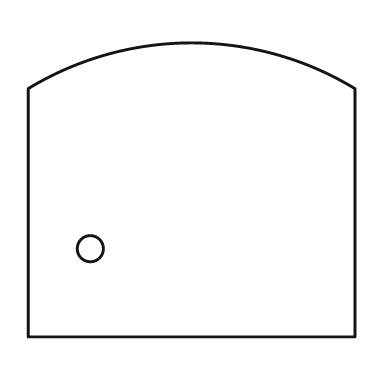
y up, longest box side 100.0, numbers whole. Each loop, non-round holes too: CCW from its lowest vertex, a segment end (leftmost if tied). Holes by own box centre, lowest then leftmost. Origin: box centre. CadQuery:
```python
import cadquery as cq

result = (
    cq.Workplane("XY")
    .moveTo(-50.0, -45.0)
    .lineTo(50.0, -45.0)
    .lineTo(50.0, 31.0)
    .threePointArc((0.0, 45.0), (-50.0, 31.0))
    .close()
    .moveTo(-31.0, -18.0)
    .circle(4.0)
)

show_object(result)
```